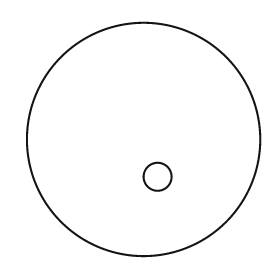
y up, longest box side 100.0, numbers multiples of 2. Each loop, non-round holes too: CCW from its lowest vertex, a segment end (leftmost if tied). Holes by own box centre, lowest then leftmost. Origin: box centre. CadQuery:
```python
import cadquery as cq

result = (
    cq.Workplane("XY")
    .moveTo(0.0, 0.0)
    .circle(50.0)
    .moveTo(6.0, -16.0)
    .circle(6.0)
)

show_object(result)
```